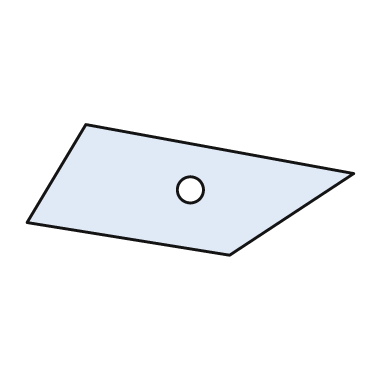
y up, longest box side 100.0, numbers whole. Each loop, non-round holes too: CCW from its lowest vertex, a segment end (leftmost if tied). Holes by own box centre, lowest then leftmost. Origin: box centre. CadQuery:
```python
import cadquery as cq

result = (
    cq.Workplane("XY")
    .moveTo(12.0, -20.0)
    .lineTo(50.0, 5.0)
    .lineTo(-32.0, 20.0)
    .lineTo(-50.0, -10.0)
    .close()
    .moveTo(0.0, 0.0)
    .circle(4.0)
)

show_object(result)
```